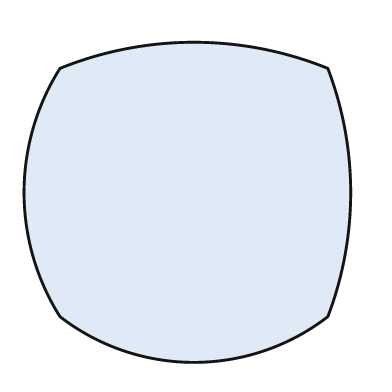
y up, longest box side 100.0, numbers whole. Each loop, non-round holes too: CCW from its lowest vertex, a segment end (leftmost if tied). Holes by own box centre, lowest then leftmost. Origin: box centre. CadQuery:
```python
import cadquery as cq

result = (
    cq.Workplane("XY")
    .moveTo(-39.0, -35.0)
    .threePointArc((2.0, -49.0), (43.0, -35.0))
    .threePointArc((50.0, 3.0), (43.0, 41.0))
    .threePointArc((2.0, 49.0), (-39.0, 41.0))
    .threePointArc((-50.0, 3.0), (-39.0, -35.0))
    .close()
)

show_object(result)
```